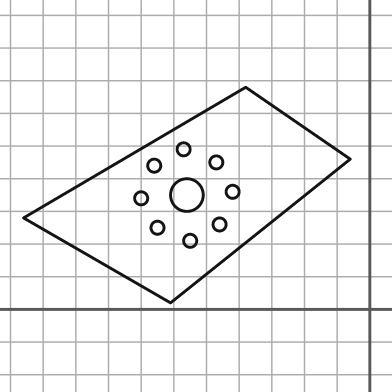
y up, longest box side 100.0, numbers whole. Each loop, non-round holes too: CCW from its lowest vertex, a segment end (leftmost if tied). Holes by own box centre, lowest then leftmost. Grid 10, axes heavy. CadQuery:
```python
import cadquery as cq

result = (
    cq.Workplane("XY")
    .moveTo(-61.0, 2.0)
    .lineTo(-6.0, 46.0)
    .lineTo(-38.0, 68.0)
    .lineTo(-106.0, 28.0)
    .close()
    .moveTo(-55.0, 21.0)
    .circle(2.0)
    .moveTo(-65.0, 25.0)
    .circle(2.0)
    .moveTo(-46.0, 26.0)
    .circle(2.0)
    .moveTo(-70.0, 34.0)
    .circle(2.0)
    .moveTo(-56.0, 35.0)
    .circle(5.0)
    .moveTo(-42.0, 36.0)
    .circle(2.0)
    .moveTo(-66.0, 44.0)
    .circle(2.0)
    .moveTo(-47.0, 45.0)
    .circle(2.0)
    .moveTo(-57.0, 49.0)
    .circle(2.0)
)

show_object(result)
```